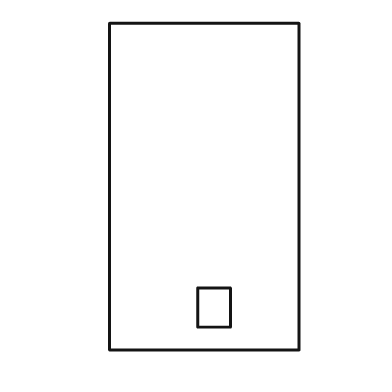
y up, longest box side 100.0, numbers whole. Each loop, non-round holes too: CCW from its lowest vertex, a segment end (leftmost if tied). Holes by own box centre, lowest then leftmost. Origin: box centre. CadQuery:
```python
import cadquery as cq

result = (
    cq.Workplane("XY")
    .moveTo(-29.0, -50.0)
    .lineTo(29.0, -50.0)
    .lineTo(29.0, 50.0)
    .lineTo(-29.0, 50.0)
    .close()
    .moveTo(-2.0, -43.0)
    .lineTo(8.0, -43.0)
    .lineTo(8.0, -31.0)
    .lineTo(-2.0, -31.0)
    .close()
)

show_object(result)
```